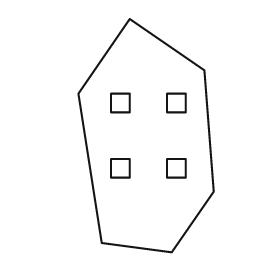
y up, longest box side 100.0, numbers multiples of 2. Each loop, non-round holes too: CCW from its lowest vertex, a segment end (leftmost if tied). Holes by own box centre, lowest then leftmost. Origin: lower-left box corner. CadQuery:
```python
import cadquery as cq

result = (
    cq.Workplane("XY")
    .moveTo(40.0, 0.0)
    .lineTo(58.0, 26.0)
    .lineTo(54.0, 78.0)
    .lineTo(22.0, 100.0)
    .lineTo(0.0, 68.0)
    .lineTo(10.0, 4.0)
    .close()
    .moveTo(14.0, 32.0)
    .lineTo(22.0, 32.0)
    .lineTo(22.0, 40.0)
    .lineTo(14.0, 40.0)
    .close()
    .moveTo(38.0, 32.0)
    .lineTo(46.0, 32.0)
    .lineTo(46.0, 40.0)
    .lineTo(38.0, 40.0)
    .close()
    .moveTo(14.0, 60.0)
    .lineTo(22.0, 60.0)
    .lineTo(22.0, 68.0)
    .lineTo(14.0, 68.0)
    .close()
    .moveTo(38.0, 60.0)
    .lineTo(46.0, 60.0)
    .lineTo(46.0, 68.0)
    .lineTo(38.0, 68.0)
    .close()
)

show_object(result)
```